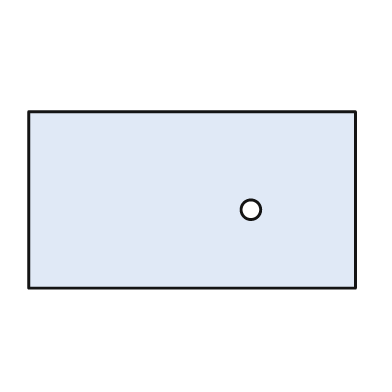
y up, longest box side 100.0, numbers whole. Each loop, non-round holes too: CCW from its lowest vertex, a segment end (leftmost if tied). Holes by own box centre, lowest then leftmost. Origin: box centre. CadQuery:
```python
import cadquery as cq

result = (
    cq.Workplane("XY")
    .moveTo(-50.0, -27.0)
    .lineTo(50.0, -27.0)
    .lineTo(50.0, 27.0)
    .lineTo(-50.0, 27.0)
    .close()
    .moveTo(18.0, -3.0)
    .circle(3.0)
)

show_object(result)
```